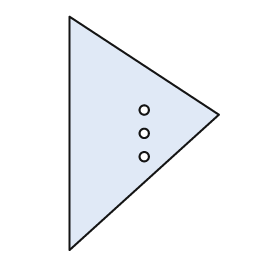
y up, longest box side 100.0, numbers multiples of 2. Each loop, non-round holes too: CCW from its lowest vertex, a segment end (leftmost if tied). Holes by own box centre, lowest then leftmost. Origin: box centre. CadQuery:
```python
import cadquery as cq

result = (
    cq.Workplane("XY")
    .moveTo(-32.0, -50.0)
    .lineTo(32.0, 8.0)
    .lineTo(-32.0, 50.0)
    .close()
    .moveTo(0.0, -10.0)
    .circle(2.0)
    .moveTo(0.0, 0.0)
    .circle(2.0)
    .moveTo(0.0, 10.0)
    .circle(2.0)
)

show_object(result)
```